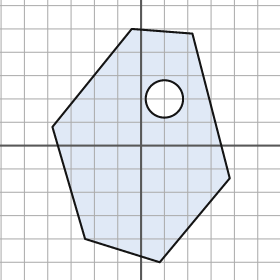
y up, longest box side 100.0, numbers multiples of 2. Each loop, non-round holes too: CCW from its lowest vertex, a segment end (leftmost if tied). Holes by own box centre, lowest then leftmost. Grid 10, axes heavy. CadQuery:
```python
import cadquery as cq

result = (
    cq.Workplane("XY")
    .moveTo(8.0, -50.0)
    .lineTo(38.0, -14.0)
    .lineTo(22.0, 48.0)
    .lineTo(-4.0, 50.0)
    .lineTo(-38.0, 8.0)
    .lineTo(-24.0, -40.0)
    .close()
    .moveTo(10.0, 20.0)
    .circle(8.0)
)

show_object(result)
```